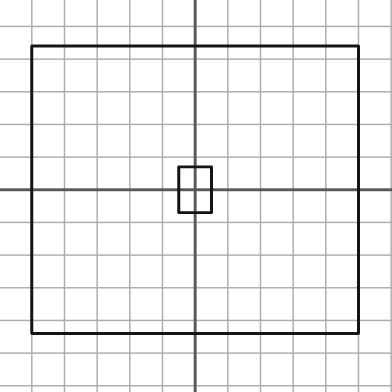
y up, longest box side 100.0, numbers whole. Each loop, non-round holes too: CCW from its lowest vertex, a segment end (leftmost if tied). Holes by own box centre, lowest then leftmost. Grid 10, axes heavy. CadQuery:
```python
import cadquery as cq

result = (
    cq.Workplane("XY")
    .moveTo(-50.0, -44.0)
    .lineTo(50.0, -44.0)
    .lineTo(50.0, 44.0)
    .lineTo(-50.0, 44.0)
    .close()
    .moveTo(-5.0, -7.0)
    .lineTo(5.0, -7.0)
    .lineTo(5.0, 7.0)
    .lineTo(-5.0, 7.0)
    .close()
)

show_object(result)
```